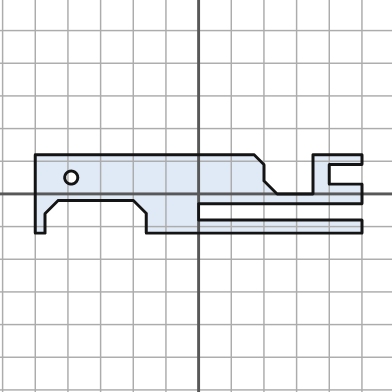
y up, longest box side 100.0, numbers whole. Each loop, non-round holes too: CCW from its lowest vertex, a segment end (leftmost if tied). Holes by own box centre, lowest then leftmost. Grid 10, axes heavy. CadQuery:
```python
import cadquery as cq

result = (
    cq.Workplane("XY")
    .moveTo(-50.0, -12.0)
    .lineTo(-47.0, -12.0)
    .lineTo(-47.0, -6.0)
    .lineTo(-43.0, -2.0)
    .lineTo(-20.0, -2.0)
    .lineTo(-16.0, -6.0)
    .lineTo(-16.0, -12.0)
    .lineTo(50.0, -12.0)
    .lineTo(50.0, -8.0)
    .lineTo(0.0, -8.0)
    .lineTo(0.0, -3.0)
    .lineTo(50.0, -3.0)
    .lineTo(50.0, 3.0)
    .lineTo(40.0, 3.0)
    .lineTo(40.0, 9.0)
    .lineTo(50.0, 9.0)
    .lineTo(50.0, 12.0)
    .lineTo(35.0, 12.0)
    .lineTo(35.0, 0.0)
    .lineTo(24.0, 0.0)
    .lineTo(20.0, 4.0)
    .lineTo(20.0, 9.0)
    .lineTo(17.0, 12.0)
    .lineTo(-50.0, 12.0)
    .close()
    .moveTo(-39.0, 5.0)
    .circle(2.0)
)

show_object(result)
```